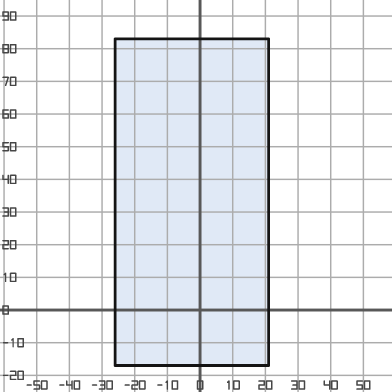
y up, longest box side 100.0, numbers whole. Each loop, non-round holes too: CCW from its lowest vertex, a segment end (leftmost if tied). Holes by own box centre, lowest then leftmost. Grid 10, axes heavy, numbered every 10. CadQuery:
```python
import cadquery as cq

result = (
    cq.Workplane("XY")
    .moveTo(-26.0, -17.0)
    .lineTo(21.0, -17.0)
    .lineTo(21.0, 83.0)
    .lineTo(-26.0, 83.0)
    .close()
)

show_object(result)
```